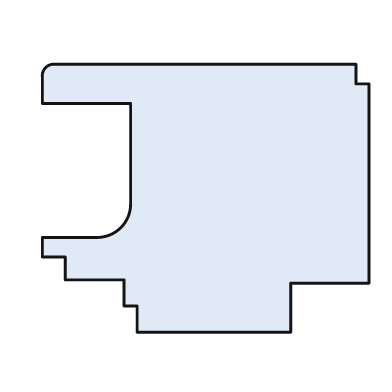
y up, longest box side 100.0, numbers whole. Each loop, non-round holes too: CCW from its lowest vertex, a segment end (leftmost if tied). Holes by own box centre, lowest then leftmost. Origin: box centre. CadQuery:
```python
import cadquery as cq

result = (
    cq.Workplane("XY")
    .moveTo(-21.0, -41.0)
    .lineTo(26.0, -41.0)
    .lineTo(26.0, -26.0)
    .lineTo(50.0, -26.0)
    .lineTo(50.0, 35.0)
    .lineTo(46.0, 35.0)
    .lineTo(46.0, 41.0)
    .lineTo(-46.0, 41.0)
    .threePointArc((-49.0, 40.0), (-50.0, 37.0))
    .lineTo(-50.0, 29.0)
    .lineTo(-23.0, 29.0)
    .lineTo(-23.0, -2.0)
    .threePointArc((-26.0, -9.0), (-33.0, -12.0))
    .lineTo(-50.0, -12.0)
    .lineTo(-50.0, -18.0)
    .lineTo(-43.0, -18.0)
    .lineTo(-43.0, -25.0)
    .lineTo(-25.0, -25.0)
    .lineTo(-25.0, -33.0)
    .lineTo(-21.0, -33.0)
    .close()
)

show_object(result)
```